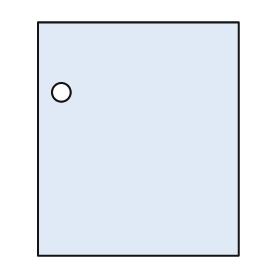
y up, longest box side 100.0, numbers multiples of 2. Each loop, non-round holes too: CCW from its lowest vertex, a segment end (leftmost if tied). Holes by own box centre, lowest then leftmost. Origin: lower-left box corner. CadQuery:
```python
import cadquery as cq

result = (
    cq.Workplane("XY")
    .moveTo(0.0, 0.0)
    .lineTo(86.0, 0.0)
    .lineTo(86.0, 100.0)
    .lineTo(0.0, 100.0)
    .close()
    .moveTo(10.0, 70.0)
    .circle(4.0)
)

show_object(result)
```